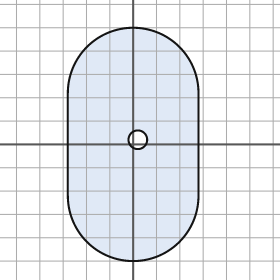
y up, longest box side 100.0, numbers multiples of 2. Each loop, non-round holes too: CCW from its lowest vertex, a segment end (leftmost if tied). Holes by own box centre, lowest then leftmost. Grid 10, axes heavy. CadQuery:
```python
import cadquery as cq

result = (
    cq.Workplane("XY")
    .moveTo(-28.0, -22.0)
    .threePointArc((0.0, -50.0), (28.0, -22.0))
    .lineTo(28.0, 22.0)
    .threePointArc((0.0, 50.0), (-28.0, 22.0))
    .close()
    .moveTo(2.0, 2.0)
    .circle(4.0)
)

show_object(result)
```